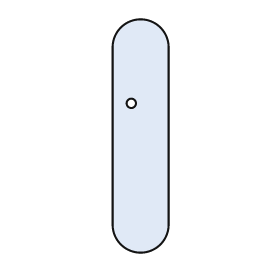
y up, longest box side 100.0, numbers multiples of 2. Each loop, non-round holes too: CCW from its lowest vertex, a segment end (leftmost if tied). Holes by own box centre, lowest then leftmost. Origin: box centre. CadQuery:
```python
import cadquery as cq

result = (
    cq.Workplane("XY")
    .moveTo(-12.0, -38.0)
    .threePointArc((0.0, -50.0), (12.0, -38.0))
    .lineTo(12.0, 38.0)
    .threePointArc((0.0, 50.0), (-12.0, 38.0))
    .close()
    .moveTo(-4.0, 14.0)
    .circle(2.0)
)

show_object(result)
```